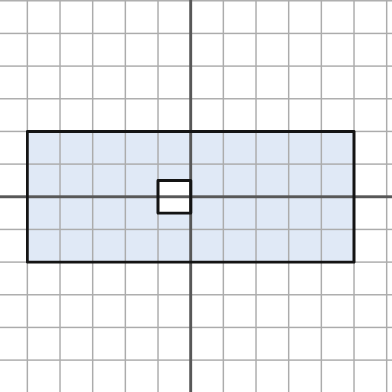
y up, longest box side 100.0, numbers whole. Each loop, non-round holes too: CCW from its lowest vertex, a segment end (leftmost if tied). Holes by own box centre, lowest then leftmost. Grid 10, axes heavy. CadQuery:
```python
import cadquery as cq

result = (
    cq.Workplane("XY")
    .moveTo(-50.0, -20.0)
    .lineTo(50.0, -20.0)
    .lineTo(50.0, 20.0)
    .lineTo(-50.0, 20.0)
    .close()
    .moveTo(-10.0, -5.0)
    .lineTo(0.0, -5.0)
    .lineTo(0.0, 5.0)
    .lineTo(-10.0, 5.0)
    .close()
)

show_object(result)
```